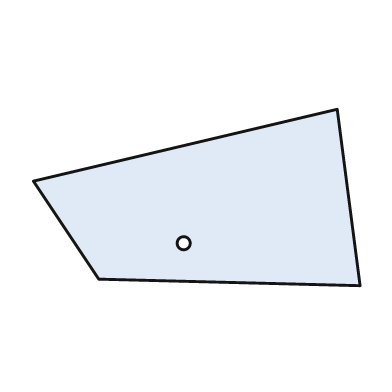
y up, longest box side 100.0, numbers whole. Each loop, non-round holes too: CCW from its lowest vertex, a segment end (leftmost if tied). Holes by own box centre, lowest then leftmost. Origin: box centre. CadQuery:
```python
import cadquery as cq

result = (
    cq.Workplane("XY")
    .moveTo(50.0, -27.0)
    .lineTo(43.0, 27.0)
    .lineTo(-50.0, 5.0)
    .lineTo(-30.0, -25.0)
    .close()
    .moveTo(-4.0, -14.0)
    .circle(2.0)
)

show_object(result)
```